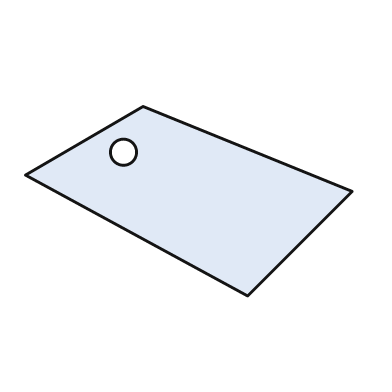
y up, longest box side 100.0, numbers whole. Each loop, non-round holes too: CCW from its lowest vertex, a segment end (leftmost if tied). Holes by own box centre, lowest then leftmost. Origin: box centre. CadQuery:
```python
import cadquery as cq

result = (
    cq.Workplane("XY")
    .moveTo(18.0, -29.0)
    .lineTo(50.0, 3.0)
    .lineTo(-14.0, 29.0)
    .lineTo(-50.0, 8.0)
    .close()
    .moveTo(-20.0, 15.0)
    .circle(4.0)
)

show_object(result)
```